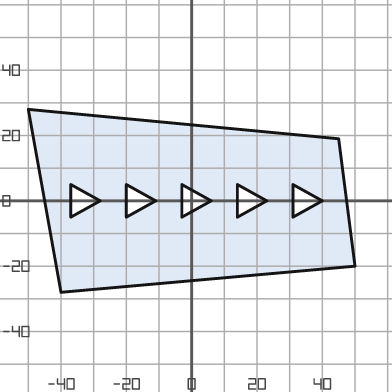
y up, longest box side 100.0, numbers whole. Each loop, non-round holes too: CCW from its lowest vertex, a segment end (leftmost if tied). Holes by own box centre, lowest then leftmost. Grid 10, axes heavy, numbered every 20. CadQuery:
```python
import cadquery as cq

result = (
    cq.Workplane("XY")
    .moveTo(-40.0, -28.0)
    .lineTo(50.0, -20.0)
    .lineTo(45.0, 19.0)
    .lineTo(-50.0, 28.0)
    .close()
    .moveTo(-37.0, -5.0)
    .lineTo(-28.0, 0.0)
    .lineTo(-37.0, 5.0)
    .close()
    .moveTo(-20.0, -5.0)
    .lineTo(-11.0, 0.0)
    .lineTo(-20.0, 5.0)
    .close()
    .moveTo(-3.0, -5.0)
    .lineTo(6.0, 0.0)
    .lineTo(-3.0, 5.0)
    .close()
    .moveTo(14.0, -5.0)
    .lineTo(23.0, 0.0)
    .lineTo(14.0, 5.0)
    .close()
    .moveTo(31.0, -5.0)
    .lineTo(40.0, 0.0)
    .lineTo(31.0, 5.0)
    .close()
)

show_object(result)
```